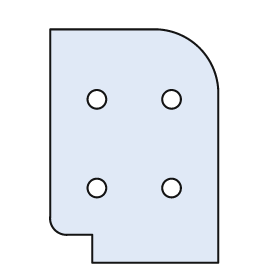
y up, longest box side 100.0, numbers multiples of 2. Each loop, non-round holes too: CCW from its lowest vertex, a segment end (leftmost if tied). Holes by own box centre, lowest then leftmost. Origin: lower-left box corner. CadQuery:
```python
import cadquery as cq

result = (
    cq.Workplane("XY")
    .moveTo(18.0, 0.0)
    .lineTo(72.0, 0.0)
    .lineTo(72.0, 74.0)
    .threePointArc((64.0, 92.0), (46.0, 100.0))
    .lineTo(0.0, 100.0)
    .lineTo(0.0, 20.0)
    .threePointArc((2.0, 14.0), (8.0, 12.0))
    .lineTo(18.0, 12.0)
    .close()
    .moveTo(20.0, 32.0)
    .circle(4.0)
    .moveTo(52.0, 32.0)
    .circle(4.0)
    .moveTo(20.0, 70.0)
    .circle(4.0)
    .moveTo(52.0, 70.0)
    .circle(4.0)
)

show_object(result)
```